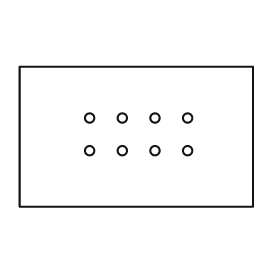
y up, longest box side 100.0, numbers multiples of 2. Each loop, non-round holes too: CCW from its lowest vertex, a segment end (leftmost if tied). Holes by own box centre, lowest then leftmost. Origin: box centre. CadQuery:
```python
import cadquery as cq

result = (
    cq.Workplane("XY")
    .moveTo(-50.0, -30.0)
    .lineTo(50.0, -30.0)
    .lineTo(50.0, 30.0)
    .lineTo(-50.0, 30.0)
    .close()
    .moveTo(-20.0, -6.0)
    .circle(2.0)
    .moveTo(-6.0, -6.0)
    .circle(2.0)
    .moveTo(8.0, -6.0)
    .circle(2.0)
    .moveTo(22.0, -6.0)
    .circle(2.0)
    .moveTo(-20.0, 8.0)
    .circle(2.0)
    .moveTo(-6.0, 8.0)
    .circle(2.0)
    .moveTo(8.0, 8.0)
    .circle(2.0)
    .moveTo(22.0, 8.0)
    .circle(2.0)
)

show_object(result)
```